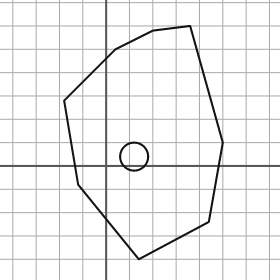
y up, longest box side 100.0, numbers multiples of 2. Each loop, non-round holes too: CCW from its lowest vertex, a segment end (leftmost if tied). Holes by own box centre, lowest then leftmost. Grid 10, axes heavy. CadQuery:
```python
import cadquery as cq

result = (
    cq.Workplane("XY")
    .moveTo(14.0, -40.0)
    .lineTo(44.0, -24.0)
    .lineTo(50.0, 10.0)
    .lineTo(36.0, 60.0)
    .lineTo(20.0, 58.0)
    .lineTo(4.0, 50.0)
    .lineTo(-18.0, 28.0)
    .lineTo(-12.0, -8.0)
    .close()
    .moveTo(12.0, 4.0)
    .circle(6.0)
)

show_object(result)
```